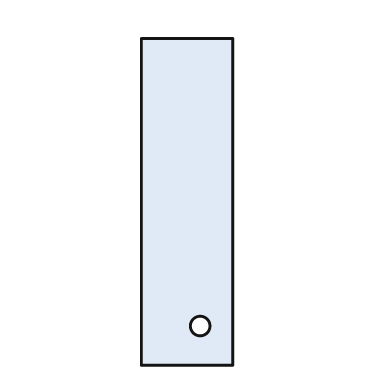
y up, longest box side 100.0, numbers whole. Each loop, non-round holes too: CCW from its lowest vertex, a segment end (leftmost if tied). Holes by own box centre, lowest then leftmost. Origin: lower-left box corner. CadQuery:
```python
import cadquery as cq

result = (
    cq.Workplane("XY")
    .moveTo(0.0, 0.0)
    .lineTo(28.0, 0.0)
    .lineTo(28.0, 100.0)
    .lineTo(0.0, 100.0)
    .close()
    .moveTo(18.0, 12.0)
    .circle(3.0)
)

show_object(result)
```